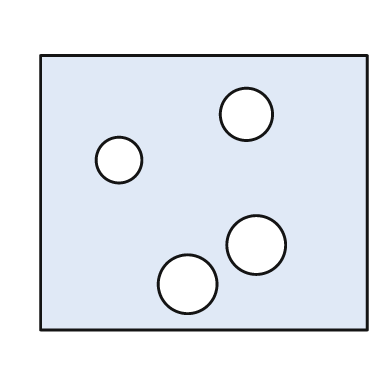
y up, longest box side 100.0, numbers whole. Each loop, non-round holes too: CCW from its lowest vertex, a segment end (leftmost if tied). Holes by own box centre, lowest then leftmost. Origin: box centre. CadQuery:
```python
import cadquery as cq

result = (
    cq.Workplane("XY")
    .moveTo(-50.0, -42.0)
    .lineTo(50.0, -42.0)
    .lineTo(50.0, 42.0)
    .lineTo(-50.0, 42.0)
    .close()
    .moveTo(-5.0, -28.0)
    .circle(9.0)
    .moveTo(16.0, -16.0)
    .circle(9.0)
    .moveTo(-26.0, 10.0)
    .circle(7.0)
    .moveTo(13.0, 24.0)
    .circle(8.0)
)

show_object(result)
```